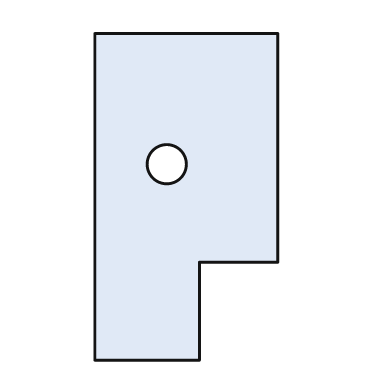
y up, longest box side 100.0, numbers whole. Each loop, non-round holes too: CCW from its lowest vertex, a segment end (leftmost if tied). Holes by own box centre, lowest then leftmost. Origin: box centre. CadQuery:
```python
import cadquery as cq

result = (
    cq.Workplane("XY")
    .moveTo(-28.0, -50.0)
    .lineTo(4.0, -50.0)
    .lineTo(4.0, -20.0)
    .lineTo(28.0, -20.0)
    .lineTo(28.0, 50.0)
    .lineTo(-28.0, 50.0)
    .close()
    .moveTo(-6.0, 10.0)
    .circle(6.0)
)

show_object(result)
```